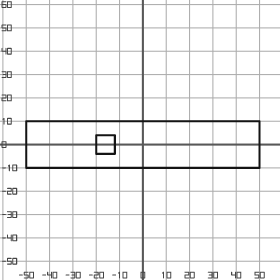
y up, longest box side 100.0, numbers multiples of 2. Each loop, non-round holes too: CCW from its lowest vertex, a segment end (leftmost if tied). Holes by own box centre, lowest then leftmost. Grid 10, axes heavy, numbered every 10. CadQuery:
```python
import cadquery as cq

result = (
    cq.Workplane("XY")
    .moveTo(-50.0, -10.0)
    .lineTo(50.0, -10.0)
    .lineTo(50.0, 10.0)
    .lineTo(-50.0, 10.0)
    .close()
    .moveTo(-20.0, -4.0)
    .lineTo(-12.0, -4.0)
    .lineTo(-12.0, 4.0)
    .lineTo(-20.0, 4.0)
    .close()
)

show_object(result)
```